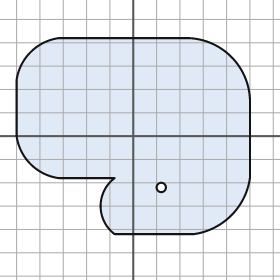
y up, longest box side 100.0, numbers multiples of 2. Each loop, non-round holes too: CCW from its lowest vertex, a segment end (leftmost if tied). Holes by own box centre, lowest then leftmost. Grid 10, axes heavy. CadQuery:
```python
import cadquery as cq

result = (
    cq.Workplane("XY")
    .moveTo(-8.0, -42.0)
    .lineTo(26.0, -42.0)
    .threePointArc((42.0, -34.0), (50.0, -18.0))
    .lineTo(50.0, 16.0)
    .threePointArc((42.0, 34.0), (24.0, 42.0))
    .lineTo(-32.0, 42.0)
    .threePointArc((-44.0, 36.0), (-50.0, 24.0))
    .lineTo(-50.0, 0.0)
    .threePointArc((-44.0, -12.0), (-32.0, -18.0))
    .lineTo(-8.0, -18.0)
    .threePointArc((-14.0, -30.0), (-8.0, -42.0))
    .close()
    .moveTo(12.0, -22.0)
    .circle(2.0)
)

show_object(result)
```